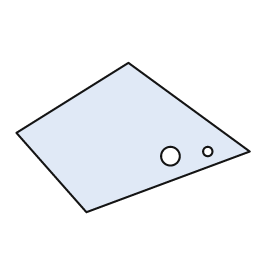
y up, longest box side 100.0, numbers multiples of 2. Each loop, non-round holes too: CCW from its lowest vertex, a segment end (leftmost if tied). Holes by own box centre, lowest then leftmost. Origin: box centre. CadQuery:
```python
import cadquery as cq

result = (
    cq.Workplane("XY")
    .moveTo(-20.0, -32.0)
    .lineTo(50.0, -6.0)
    .lineTo(-2.0, 32.0)
    .lineTo(-50.0, 2.0)
    .close()
    .moveTo(16.0, -8.0)
    .circle(4.0)
    .moveTo(32.0, -6.0)
    .circle(2.0)
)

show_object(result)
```